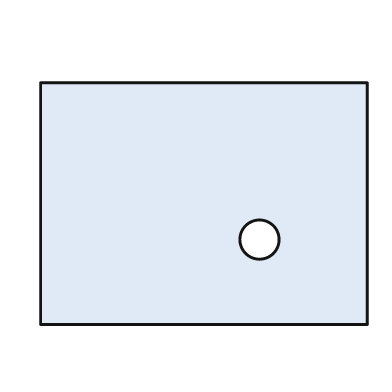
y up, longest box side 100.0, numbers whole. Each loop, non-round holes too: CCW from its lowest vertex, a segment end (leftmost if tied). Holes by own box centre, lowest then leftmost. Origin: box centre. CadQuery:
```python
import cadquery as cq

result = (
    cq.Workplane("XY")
    .moveTo(-50.0, -37.0)
    .lineTo(50.0, -37.0)
    .lineTo(50.0, 37.0)
    .lineTo(-50.0, 37.0)
    .close()
    .moveTo(17.0, -11.0)
    .circle(6.0)
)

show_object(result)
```